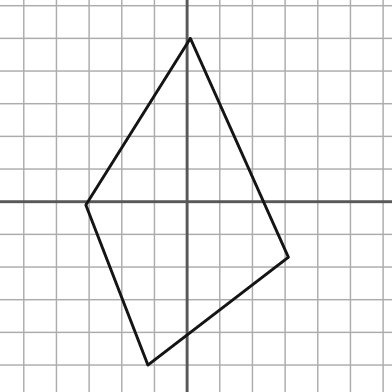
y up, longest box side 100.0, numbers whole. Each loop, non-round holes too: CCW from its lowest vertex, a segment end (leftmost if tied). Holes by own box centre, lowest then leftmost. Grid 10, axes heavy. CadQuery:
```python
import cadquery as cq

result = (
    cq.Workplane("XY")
    .moveTo(-12.0, -50.0)
    .lineTo(31.0, -17.0)
    .lineTo(1.0, 50.0)
    .lineTo(-31.0, -1.0)
    .close()
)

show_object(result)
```